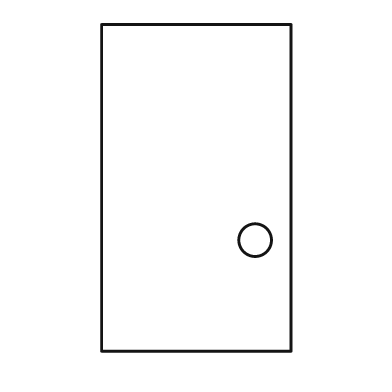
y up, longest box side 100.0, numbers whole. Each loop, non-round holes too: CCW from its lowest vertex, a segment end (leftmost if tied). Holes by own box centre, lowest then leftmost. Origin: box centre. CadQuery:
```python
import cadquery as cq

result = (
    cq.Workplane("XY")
    .moveTo(-29.0, -50.0)
    .lineTo(29.0, -50.0)
    .lineTo(29.0, 50.0)
    .lineTo(-29.0, 50.0)
    .close()
    .moveTo(18.0, -16.0)
    .circle(5.0)
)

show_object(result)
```